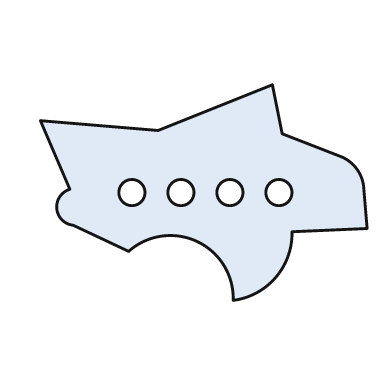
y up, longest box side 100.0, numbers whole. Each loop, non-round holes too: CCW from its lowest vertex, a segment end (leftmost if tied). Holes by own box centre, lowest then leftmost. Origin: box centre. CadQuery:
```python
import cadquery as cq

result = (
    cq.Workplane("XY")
    .moveTo(9.0, -33.0)
    .threePointArc((22.0, -26.0), (27.0, -12.0))
    .lineTo(50.0, -11.0)
    .lineTo(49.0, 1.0)
    .threePointArc((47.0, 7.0), (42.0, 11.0))
    .lineTo(24.0, 18.0)
    .lineTo(21.0, 33.0)
    .lineTo(-14.0, 19.0)
    .lineTo(-50.0, 22.0)
    .lineTo(-41.0, 1.0)
    .threePointArc((-45.0, -5.0), (-40.0, -10.0))
    .lineTo(-23.0, -18.0)
    .threePointArc((-2.0, -15.0), (9.0, -33.0))
    .close()
    .moveTo(-22.0, 0.0)
    .circle(4.0)
    .moveTo(-7.0, 0.0)
    .circle(4.0)
    .moveTo(8.0, 0.0)
    .circle(4.0)
    .moveTo(23.0, 0.0)
    .circle(4.0)
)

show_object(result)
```